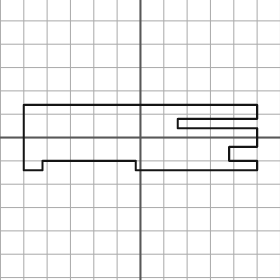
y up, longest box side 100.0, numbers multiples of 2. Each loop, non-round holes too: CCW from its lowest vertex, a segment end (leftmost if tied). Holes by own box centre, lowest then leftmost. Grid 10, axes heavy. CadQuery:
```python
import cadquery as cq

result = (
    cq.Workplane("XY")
    .moveTo(-50.0, -14.0)
    .lineTo(-42.0, -14.0)
    .lineTo(-42.0, -10.0)
    .lineTo(-2.0, -10.0)
    .lineTo(-2.0, -14.0)
    .lineTo(50.0, -14.0)
    .lineTo(50.0, -10.0)
    .lineTo(38.0, -10.0)
    .lineTo(38.0, -4.0)
    .lineTo(50.0, -4.0)
    .lineTo(50.0, 4.0)
    .lineTo(16.0, 4.0)
    .lineTo(16.0, 8.0)
    .lineTo(50.0, 8.0)
    .lineTo(50.0, 14.0)
    .lineTo(-50.0, 14.0)
    .close()
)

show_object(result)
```